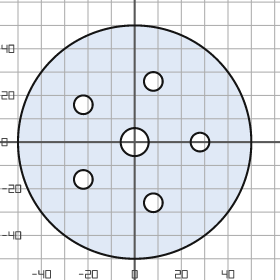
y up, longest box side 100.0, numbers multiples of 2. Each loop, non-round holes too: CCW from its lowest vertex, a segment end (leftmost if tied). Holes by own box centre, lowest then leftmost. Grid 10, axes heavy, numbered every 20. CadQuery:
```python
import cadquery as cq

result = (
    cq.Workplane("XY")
    .moveTo(0.0, 0.0)
    .circle(50.0)
    .moveTo(8.0, -26.0)
    .circle(4.0)
    .moveTo(-22.0, -16.0)
    .circle(4.0)
    .moveTo(0.0, 0.0)
    .circle(6.0)
    .moveTo(28.0, 0.0)
    .circle(4.0)
    .moveTo(-22.0, 16.0)
    .circle(4.0)
    .moveTo(8.0, 26.0)
    .circle(4.0)
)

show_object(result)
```